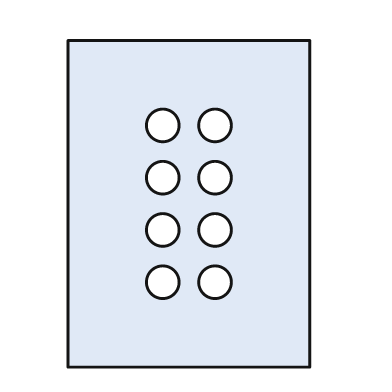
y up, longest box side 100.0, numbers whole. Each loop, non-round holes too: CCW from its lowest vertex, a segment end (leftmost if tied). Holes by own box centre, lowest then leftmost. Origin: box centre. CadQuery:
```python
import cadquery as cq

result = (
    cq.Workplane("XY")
    .moveTo(-37.0, -50.0)
    .lineTo(37.0, -50.0)
    .lineTo(37.0, 50.0)
    .lineTo(-37.0, 50.0)
    .close()
    .moveTo(-8.0, -24.0)
    .circle(5.0)
    .moveTo(8.0, -24.0)
    .circle(5.0)
    .moveTo(-8.0, -8.0)
    .circle(5.0)
    .moveTo(8.0, -8.0)
    .circle(5.0)
    .moveTo(-8.0, 8.0)
    .circle(5.0)
    .moveTo(8.0, 8.0)
    .circle(5.0)
    .moveTo(-8.0, 24.0)
    .circle(5.0)
    .moveTo(8.0, 24.0)
    .circle(5.0)
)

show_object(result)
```